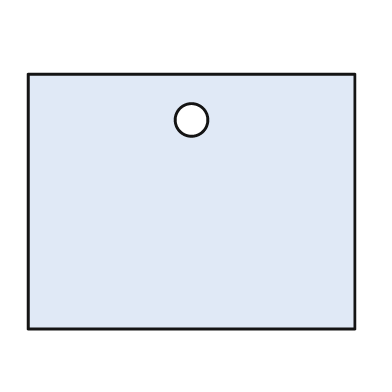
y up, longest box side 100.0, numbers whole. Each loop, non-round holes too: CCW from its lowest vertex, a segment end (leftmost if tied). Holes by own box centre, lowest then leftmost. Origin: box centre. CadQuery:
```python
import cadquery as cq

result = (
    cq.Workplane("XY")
    .moveTo(-50.0, -39.0)
    .lineTo(50.0, -39.0)
    .lineTo(50.0, 39.0)
    .lineTo(-50.0, 39.0)
    .close()
    .moveTo(0.0, 25.0)
    .circle(5.0)
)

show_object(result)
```